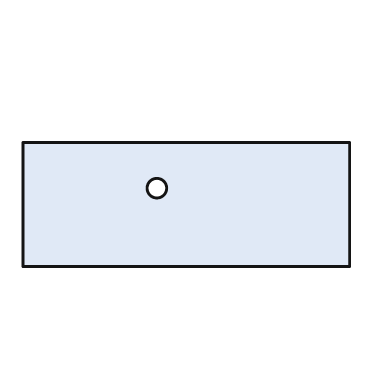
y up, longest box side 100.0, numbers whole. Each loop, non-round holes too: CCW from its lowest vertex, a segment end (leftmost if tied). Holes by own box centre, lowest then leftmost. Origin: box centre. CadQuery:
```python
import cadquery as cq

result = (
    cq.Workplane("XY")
    .moveTo(-50.0, -19.0)
    .lineTo(50.0, -19.0)
    .lineTo(50.0, 19.0)
    .lineTo(-50.0, 19.0)
    .close()
    .moveTo(-9.0, 5.0)
    .circle(3.0)
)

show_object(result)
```